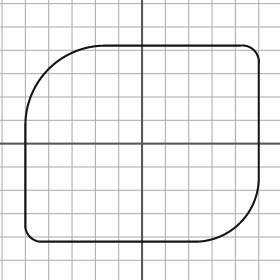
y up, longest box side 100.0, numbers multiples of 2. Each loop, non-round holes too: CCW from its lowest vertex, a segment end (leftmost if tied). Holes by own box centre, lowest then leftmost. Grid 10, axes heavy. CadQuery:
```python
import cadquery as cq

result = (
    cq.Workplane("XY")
    .moveTo(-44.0, -42.0)
    .lineTo(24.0, -42.0)
    .threePointArc((42.0, -34.0), (50.0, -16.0))
    .lineTo(50.0, 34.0)
    .threePointArc((48.0, 40.0), (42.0, 42.0))
    .lineTo(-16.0, 42.0)
    .threePointArc((-40.0, 32.0), (-50.0, 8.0))
    .lineTo(-50.0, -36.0)
    .threePointArc((-48.0, -40.0), (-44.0, -42.0))
    .close()
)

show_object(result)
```